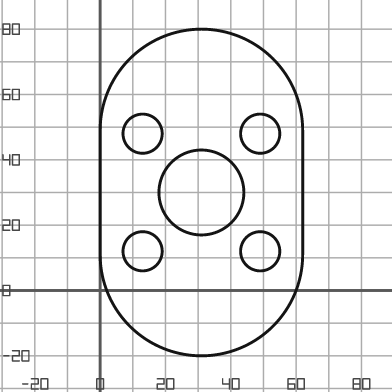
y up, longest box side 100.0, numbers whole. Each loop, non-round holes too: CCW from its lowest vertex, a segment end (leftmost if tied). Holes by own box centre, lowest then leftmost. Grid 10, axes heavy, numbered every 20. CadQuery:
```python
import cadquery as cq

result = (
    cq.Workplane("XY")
    .moveTo(0.0, 11.0)
    .threePointArc((31.0, -20.0), (62.0, 11.0))
    .lineTo(62.0, 49.0)
    .threePointArc((31.0, 80.0), (0.0, 49.0))
    .close()
    .moveTo(13.0, 12.0)
    .circle(6.0)
    .moveTo(49.0, 12.0)
    .circle(6.0)
    .moveTo(31.0, 30.0)
    .circle(13.0)
    .moveTo(13.0, 48.0)
    .circle(6.0)
    .moveTo(49.0, 48.0)
    .circle(6.0)
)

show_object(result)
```